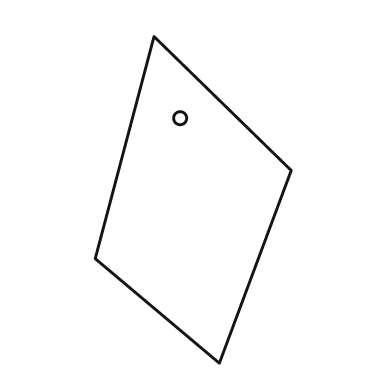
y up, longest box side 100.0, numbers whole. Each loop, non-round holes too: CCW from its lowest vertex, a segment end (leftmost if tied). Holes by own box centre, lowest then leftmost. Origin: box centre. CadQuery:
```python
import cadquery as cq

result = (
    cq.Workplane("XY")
    .moveTo(8.0, -50.0)
    .lineTo(30.0, 9.0)
    .lineTo(-12.0, 50.0)
    .lineTo(-30.0, -18.0)
    .close()
    .moveTo(-4.0, 25.0)
    .circle(2.0)
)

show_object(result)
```